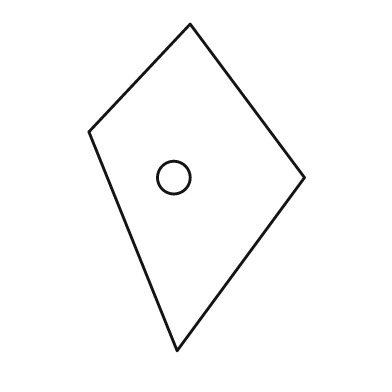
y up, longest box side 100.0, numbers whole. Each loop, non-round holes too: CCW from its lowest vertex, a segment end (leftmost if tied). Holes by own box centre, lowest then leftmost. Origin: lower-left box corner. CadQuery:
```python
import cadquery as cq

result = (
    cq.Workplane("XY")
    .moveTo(27.0, 0.0)
    .lineTo(66.0, 53.0)
    .lineTo(31.0, 100.0)
    .lineTo(0.0, 67.0)
    .close()
    .moveTo(26.0, 53.0)
    .circle(5.0)
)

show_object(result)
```